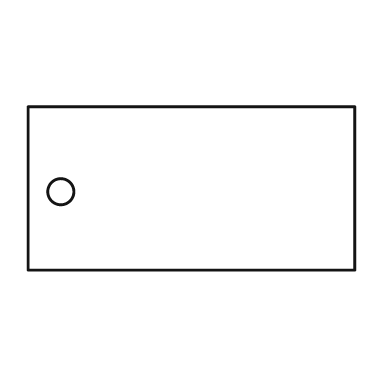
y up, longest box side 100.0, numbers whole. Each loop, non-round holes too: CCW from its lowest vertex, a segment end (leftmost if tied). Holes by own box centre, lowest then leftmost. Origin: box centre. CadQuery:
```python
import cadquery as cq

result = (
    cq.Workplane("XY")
    .moveTo(-50.0, -25.0)
    .lineTo(50.0, -25.0)
    .lineTo(50.0, 25.0)
    .lineTo(-50.0, 25.0)
    .close()
    .moveTo(-40.0, -1.0)
    .circle(4.0)
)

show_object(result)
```